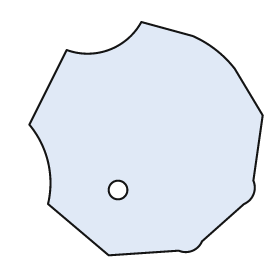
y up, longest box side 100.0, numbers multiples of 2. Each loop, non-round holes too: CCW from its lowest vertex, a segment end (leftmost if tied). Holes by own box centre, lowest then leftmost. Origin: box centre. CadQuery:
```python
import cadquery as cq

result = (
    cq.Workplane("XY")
    .moveTo(-16.0, -50.0)
    .lineTo(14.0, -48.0)
    .threePointArc((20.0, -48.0), (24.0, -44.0))
    .lineTo(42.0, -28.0)
    .threePointArc((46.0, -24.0), (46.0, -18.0))
    .lineTo(50.0, 10.0)
    .lineTo(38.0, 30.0)
    .threePointArc((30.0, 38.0), (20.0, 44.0))
    .lineTo(-2.0, 50.0)
    .threePointArc((-16.0, 38.0), (-34.0, 38.0))
    .lineTo(-50.0, 6.0)
    .threePointArc((-42.0, -10.0), (-42.0, -28.0))
    .close()
    .moveTo(-12.0, -22.0)
    .circle(4.0)
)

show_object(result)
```